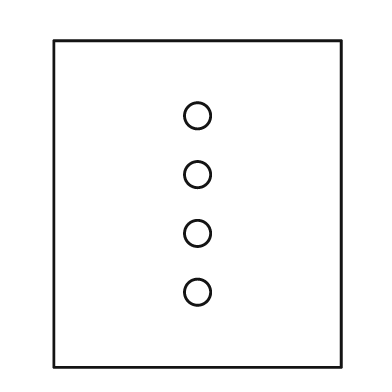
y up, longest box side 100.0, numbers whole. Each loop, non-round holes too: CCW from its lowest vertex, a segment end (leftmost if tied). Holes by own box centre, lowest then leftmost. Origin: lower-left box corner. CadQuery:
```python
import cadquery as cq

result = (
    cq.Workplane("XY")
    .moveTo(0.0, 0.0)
    .lineTo(88.0, 0.0)
    .lineTo(88.0, 100.0)
    .lineTo(0.0, 100.0)
    .close()
    .moveTo(44.0, 23.0)
    .circle(4.0)
    .moveTo(44.0, 41.0)
    .circle(4.0)
    .moveTo(44.0, 59.0)
    .circle(4.0)
    .moveTo(44.0, 77.0)
    .circle(4.0)
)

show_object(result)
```